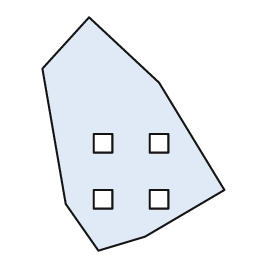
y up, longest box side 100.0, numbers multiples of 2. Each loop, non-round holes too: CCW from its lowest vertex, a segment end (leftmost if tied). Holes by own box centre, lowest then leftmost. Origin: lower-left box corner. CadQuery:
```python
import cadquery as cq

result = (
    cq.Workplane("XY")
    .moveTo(24.0, 0.0)
    .lineTo(44.0, 6.0)
    .lineTo(78.0, 26.0)
    .lineTo(50.0, 72.0)
    .lineTo(20.0, 100.0)
    .lineTo(0.0, 78.0)
    .lineTo(10.0, 20.0)
    .close()
    .moveTo(22.0, 18.0)
    .lineTo(30.0, 18.0)
    .lineTo(30.0, 26.0)
    .lineTo(22.0, 26.0)
    .close()
    .moveTo(46.0, 18.0)
    .lineTo(54.0, 18.0)
    .lineTo(54.0, 26.0)
    .lineTo(46.0, 26.0)
    .close()
    .moveTo(22.0, 42.0)
    .lineTo(30.0, 42.0)
    .lineTo(30.0, 50.0)
    .lineTo(22.0, 50.0)
    .close()
    .moveTo(46.0, 42.0)
    .lineTo(54.0, 42.0)
    .lineTo(54.0, 50.0)
    .lineTo(46.0, 50.0)
    .close()
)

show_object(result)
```